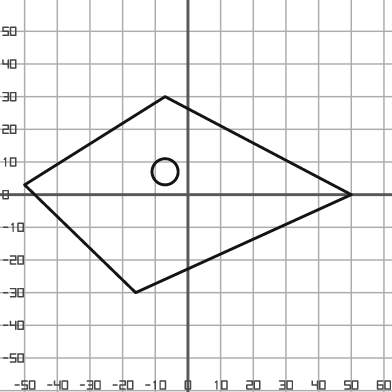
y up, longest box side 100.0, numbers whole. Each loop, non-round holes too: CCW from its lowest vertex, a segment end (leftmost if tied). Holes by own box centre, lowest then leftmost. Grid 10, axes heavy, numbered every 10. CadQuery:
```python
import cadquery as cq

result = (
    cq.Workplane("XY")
    .moveTo(-16.0, -30.0)
    .lineTo(50.0, 0.0)
    .lineTo(-7.0, 30.0)
    .lineTo(-50.0, 3.0)
    .close()
    .moveTo(-7.0, 7.0)
    .circle(4.0)
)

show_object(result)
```